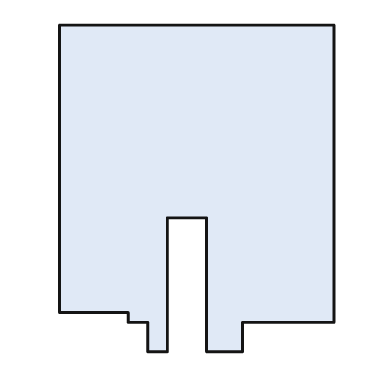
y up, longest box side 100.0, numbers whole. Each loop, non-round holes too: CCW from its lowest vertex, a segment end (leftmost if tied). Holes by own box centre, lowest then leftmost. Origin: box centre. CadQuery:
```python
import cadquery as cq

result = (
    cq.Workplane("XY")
    .moveTo(-15.0, -50.0)
    .lineTo(-9.0, -50.0)
    .lineTo(-9.0, -9.0)
    .lineTo(3.0, -9.0)
    .lineTo(3.0, -50.0)
    .lineTo(14.0, -50.0)
    .lineTo(14.0, -41.0)
    .lineTo(42.0, -41.0)
    .lineTo(42.0, 50.0)
    .lineTo(-42.0, 50.0)
    .lineTo(-42.0, -38.0)
    .lineTo(-21.0, -38.0)
    .lineTo(-21.0, -41.0)
    .lineTo(-15.0, -41.0)
    .close()
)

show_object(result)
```